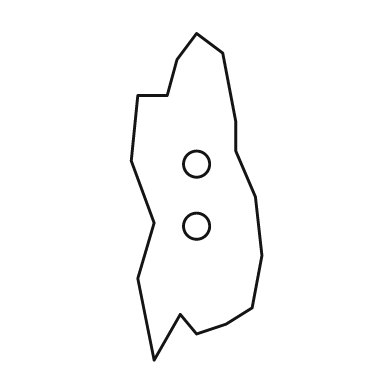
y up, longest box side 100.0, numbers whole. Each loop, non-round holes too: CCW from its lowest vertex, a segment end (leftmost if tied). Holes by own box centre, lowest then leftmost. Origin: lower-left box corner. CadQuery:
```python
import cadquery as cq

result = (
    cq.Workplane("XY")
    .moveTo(7.0, 0.0)
    .lineTo(15.0, 14.0)
    .lineTo(20.0, 8.0)
    .lineTo(29.0, 11.0)
    .lineTo(37.0, 16.0)
    .lineTo(40.0, 32.0)
    .lineTo(38.0, 50.0)
    .lineTo(32.0, 64.0)
    .lineTo(32.0, 73.0)
    .lineTo(28.0, 94.0)
    .lineTo(20.0, 100.0)
    .lineTo(14.0, 92.0)
    .lineTo(11.0, 81.0)
    .lineTo(2.0, 81.0)
    .lineTo(0.0, 61.0)
    .lineTo(7.0, 42.0)
    .lineTo(2.0, 25.0)
    .close()
    .moveTo(20.0, 41.0)
    .circle(4.0)
    .moveTo(20.0, 60.0)
    .circle(4.0)
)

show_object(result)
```